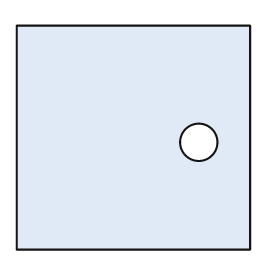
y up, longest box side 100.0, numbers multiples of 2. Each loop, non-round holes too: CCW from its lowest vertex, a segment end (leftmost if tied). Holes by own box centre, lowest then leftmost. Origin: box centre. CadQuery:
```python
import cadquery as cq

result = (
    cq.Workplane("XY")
    .moveTo(-50.0, -48.0)
    .lineTo(50.0, -48.0)
    .lineTo(50.0, 48.0)
    .lineTo(-50.0, 48.0)
    .close()
    .moveTo(28.0, -2.0)
    .circle(8.0)
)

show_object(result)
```